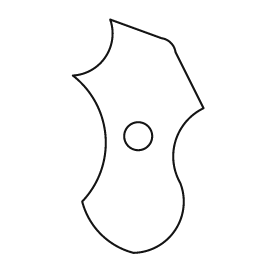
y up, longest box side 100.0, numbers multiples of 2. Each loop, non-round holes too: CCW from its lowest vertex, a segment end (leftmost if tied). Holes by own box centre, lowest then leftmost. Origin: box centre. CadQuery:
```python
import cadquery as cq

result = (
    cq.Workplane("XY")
    .moveTo(-2.0, -50.0)
    .threePointArc((16.0, -40.0), (18.0, -20.0))
    .threePointArc((16.0, -2.0), (28.0, 12.0))
    .lineTo(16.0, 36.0)
    .threePointArc((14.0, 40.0), (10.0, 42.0))
    .lineTo(-12.0, 50.0)
    .threePointArc((-14.0, 34.0), (-28.0, 26.0))
    .threePointArc((-14.0, 0.0), (-24.0, -28.0))
    .threePointArc((-16.0, -42.0), (-2.0, -50.0))
    .close()
    .moveTo(0.0, 0.0)
    .circle(6.0)
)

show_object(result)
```